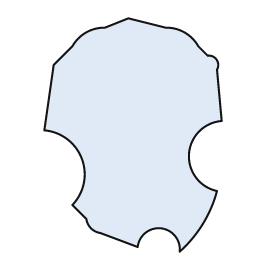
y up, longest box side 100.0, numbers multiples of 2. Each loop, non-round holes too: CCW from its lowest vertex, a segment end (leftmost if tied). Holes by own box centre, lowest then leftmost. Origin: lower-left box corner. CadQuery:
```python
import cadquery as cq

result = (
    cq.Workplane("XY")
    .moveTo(58.0, 0.0)
    .threePointArc((68.0, 12.0), (74.0, 26.0))
    .threePointArc((62.0, 42.0), (76.0, 56.0))
    .lineTo(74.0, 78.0)
    .threePointArc((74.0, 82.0), (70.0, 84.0))
    .lineTo(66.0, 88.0)
    .threePointArc((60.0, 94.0), (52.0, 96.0))
    .lineTo(36.0, 100.0)
    .lineTo(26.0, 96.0)
    .threePointArc((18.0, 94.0), (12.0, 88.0))
    .lineTo(4.0, 80.0)
    .lineTo(0.0, 52.0)
    .threePointArc((16.0, 40.0), (12.0, 20.0))
    .lineTo(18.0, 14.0)
    .threePointArc((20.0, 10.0), (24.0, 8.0))
    .lineTo(40.0, 2.0)
    .threePointArc((50.0, 10.0), (58.0, 0.0))
    .close()
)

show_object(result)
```